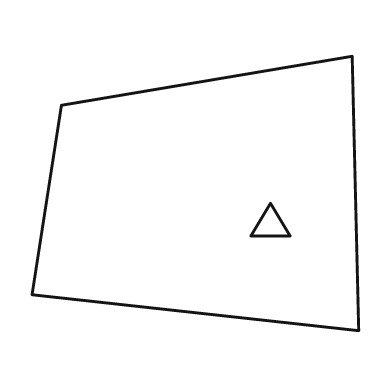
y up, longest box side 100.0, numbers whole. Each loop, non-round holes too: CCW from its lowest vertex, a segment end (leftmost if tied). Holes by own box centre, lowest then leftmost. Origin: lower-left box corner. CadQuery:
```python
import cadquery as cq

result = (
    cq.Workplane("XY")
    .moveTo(100.0, 0.0)
    .lineTo(98.0, 84.0)
    .lineTo(9.0, 69.0)
    .lineTo(0.0, 11.0)
    .close()
    .moveTo(67.0, 29.0)
    .lineTo(79.0, 29.0)
    .lineTo(73.0, 39.0)
    .close()
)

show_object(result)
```